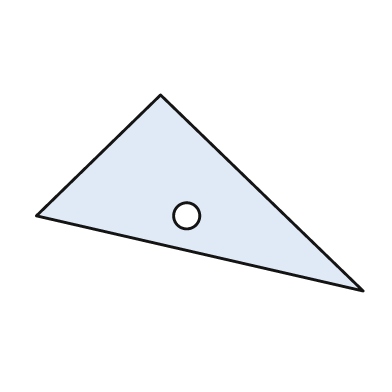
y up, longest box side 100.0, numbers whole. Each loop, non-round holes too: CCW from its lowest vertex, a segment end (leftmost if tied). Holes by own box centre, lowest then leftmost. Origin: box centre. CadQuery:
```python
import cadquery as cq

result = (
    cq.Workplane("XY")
    .moveTo(50.0, -30.0)
    .lineTo(-12.0, 30.0)
    .lineTo(-50.0, -7.0)
    .close()
    .moveTo(-4.0, -7.0)
    .circle(4.0)
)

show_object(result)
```